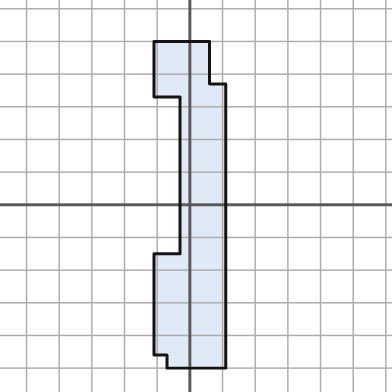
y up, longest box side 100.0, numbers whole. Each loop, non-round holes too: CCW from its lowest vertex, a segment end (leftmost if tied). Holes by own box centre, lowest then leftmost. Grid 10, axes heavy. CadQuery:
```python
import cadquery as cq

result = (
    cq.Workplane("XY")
    .moveTo(-7.0, -50.0)
    .lineTo(11.0, -50.0)
    .lineTo(11.0, 37.0)
    .lineTo(6.0, 37.0)
    .lineTo(6.0, 50.0)
    .lineTo(-11.0, 50.0)
    .lineTo(-11.0, 33.0)
    .lineTo(-3.0, 33.0)
    .lineTo(-3.0, -15.0)
    .lineTo(-11.0, -15.0)
    .lineTo(-11.0, -46.0)
    .lineTo(-7.0, -46.0)
    .close()
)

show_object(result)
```